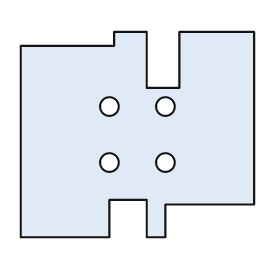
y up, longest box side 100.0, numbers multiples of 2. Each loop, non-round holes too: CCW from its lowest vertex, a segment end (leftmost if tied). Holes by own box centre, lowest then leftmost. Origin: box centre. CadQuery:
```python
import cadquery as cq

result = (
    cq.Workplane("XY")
    .moveTo(-50.0, -44.0)
    .lineTo(-12.0, -44.0)
    .lineTo(-12.0, -28.0)
    .lineTo(4.0, -28.0)
    .lineTo(4.0, -44.0)
    .lineTo(12.0, -44.0)
    .lineTo(12.0, -30.0)
    .lineTo(50.0, -30.0)
    .lineTo(50.0, 44.0)
    .lineTo(18.0, 44.0)
    .lineTo(18.0, 20.0)
    .lineTo(4.0, 20.0)
    .lineTo(4.0, 44.0)
    .lineTo(-10.0, 44.0)
    .lineTo(-10.0, 38.0)
    .lineTo(-50.0, 38.0)
    .close()
    .moveTo(-12.0, -12.0)
    .circle(4.0)
    .moveTo(12.0, -12.0)
    .circle(4.0)
    .moveTo(-12.0, 12.0)
    .circle(4.0)
    .moveTo(12.0, 12.0)
    .circle(4.0)
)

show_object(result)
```